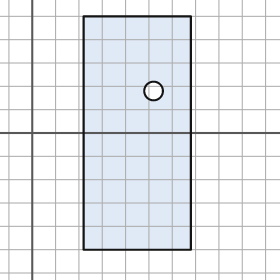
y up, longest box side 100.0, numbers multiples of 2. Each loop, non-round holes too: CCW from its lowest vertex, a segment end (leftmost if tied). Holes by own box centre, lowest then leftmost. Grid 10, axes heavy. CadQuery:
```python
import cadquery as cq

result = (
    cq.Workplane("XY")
    .moveTo(22.0, -50.0)
    .lineTo(68.0, -50.0)
    .lineTo(68.0, 50.0)
    .lineTo(22.0, 50.0)
    .close()
    .moveTo(52.0, 18.0)
    .circle(4.0)
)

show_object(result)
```